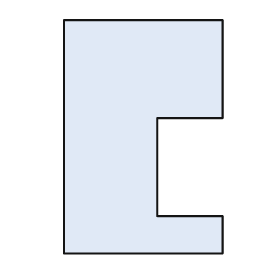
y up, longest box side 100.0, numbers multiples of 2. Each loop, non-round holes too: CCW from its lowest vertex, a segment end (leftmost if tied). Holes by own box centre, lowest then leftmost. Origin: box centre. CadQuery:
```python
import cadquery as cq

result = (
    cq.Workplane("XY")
    .moveTo(-34.0, -50.0)
    .lineTo(34.0, -50.0)
    .lineTo(34.0, -34.0)
    .lineTo(6.0, -34.0)
    .lineTo(6.0, 8.0)
    .lineTo(34.0, 8.0)
    .lineTo(34.0, 50.0)
    .lineTo(-34.0, 50.0)
    .close()
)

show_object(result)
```